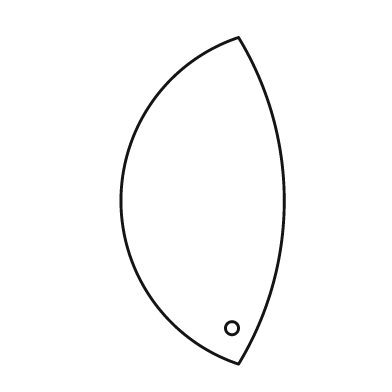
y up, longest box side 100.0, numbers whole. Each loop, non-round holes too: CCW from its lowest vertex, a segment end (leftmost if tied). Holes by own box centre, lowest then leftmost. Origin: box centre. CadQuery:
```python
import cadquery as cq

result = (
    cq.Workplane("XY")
    .moveTo(11.0, -50.0)
    .threePointArc((25.0, 0.0), (11.0, 50.0))
    .threePointArc((-25.0, 0.0), (11.0, -50.0))
    .close()
    .moveTo(9.0, -39.0)
    .circle(2.0)
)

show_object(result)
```